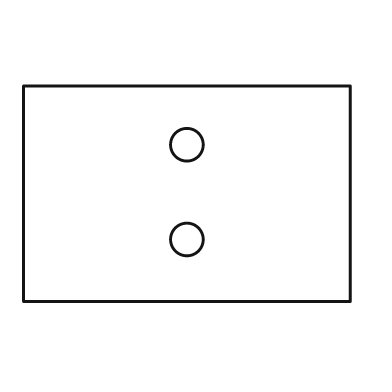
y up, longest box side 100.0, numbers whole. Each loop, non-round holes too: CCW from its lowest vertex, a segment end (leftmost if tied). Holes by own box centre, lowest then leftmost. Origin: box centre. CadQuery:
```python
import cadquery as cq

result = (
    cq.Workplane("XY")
    .moveTo(-50.0, -33.0)
    .lineTo(50.0, -33.0)
    .lineTo(50.0, 33.0)
    .lineTo(-50.0, 33.0)
    .close()
    .moveTo(0.0, -14.0)
    .circle(5.0)
    .moveTo(0.0, 15.0)
    .circle(5.0)
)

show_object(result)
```